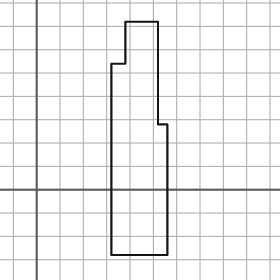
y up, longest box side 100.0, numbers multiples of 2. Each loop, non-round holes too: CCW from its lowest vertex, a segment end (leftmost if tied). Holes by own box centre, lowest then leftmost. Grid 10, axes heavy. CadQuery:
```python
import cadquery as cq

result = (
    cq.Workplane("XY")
    .moveTo(32.0, -28.0)
    .lineTo(56.0, -28.0)
    .lineTo(56.0, 28.0)
    .lineTo(52.0, 28.0)
    .lineTo(52.0, 72.0)
    .lineTo(38.0, 72.0)
    .lineTo(38.0, 54.0)
    .lineTo(32.0, 54.0)
    .close()
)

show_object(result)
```